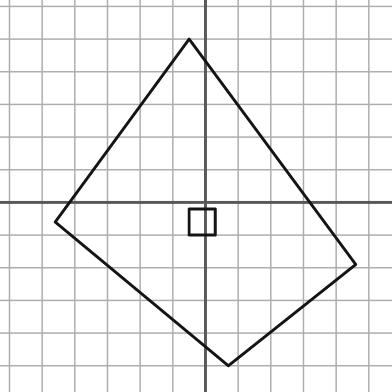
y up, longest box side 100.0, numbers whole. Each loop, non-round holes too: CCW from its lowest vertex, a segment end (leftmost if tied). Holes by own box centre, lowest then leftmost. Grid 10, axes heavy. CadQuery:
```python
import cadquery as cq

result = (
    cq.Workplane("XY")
    .moveTo(7.0, -50.0)
    .lineTo(46.0, -19.0)
    .lineTo(-5.0, 50.0)
    .lineTo(-46.0, -6.0)
    .close()
    .moveTo(-5.0, -10.0)
    .lineTo(3.0, -10.0)
    .lineTo(3.0, -2.0)
    .lineTo(-5.0, -2.0)
    .close()
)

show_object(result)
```